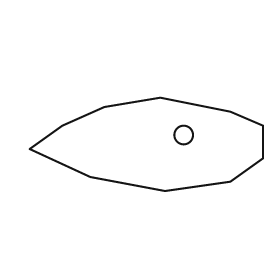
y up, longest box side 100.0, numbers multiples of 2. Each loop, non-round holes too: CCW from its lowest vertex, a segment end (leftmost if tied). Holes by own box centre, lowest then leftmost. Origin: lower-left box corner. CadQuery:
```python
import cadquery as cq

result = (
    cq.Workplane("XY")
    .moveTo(58.0, 0.0)
    .lineTo(86.0, 4.0)
    .lineTo(100.0, 14.0)
    .lineTo(100.0, 28.0)
    .lineTo(86.0, 34.0)
    .lineTo(56.0, 40.0)
    .lineTo(32.0, 36.0)
    .lineTo(14.0, 28.0)
    .lineTo(0.0, 18.0)
    .lineTo(26.0, 6.0)
    .close()
    .moveTo(66.0, 24.0)
    .circle(4.0)
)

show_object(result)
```